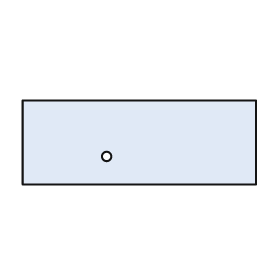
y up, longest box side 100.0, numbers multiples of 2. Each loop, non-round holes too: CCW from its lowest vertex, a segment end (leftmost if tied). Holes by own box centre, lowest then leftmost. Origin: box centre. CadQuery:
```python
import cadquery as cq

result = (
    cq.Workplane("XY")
    .moveTo(-50.0, -18.0)
    .lineTo(50.0, -18.0)
    .lineTo(50.0, 18.0)
    .lineTo(-50.0, 18.0)
    .close()
    .moveTo(-14.0, -6.0)
    .circle(2.0)
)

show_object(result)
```